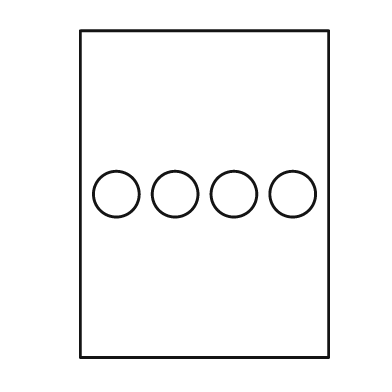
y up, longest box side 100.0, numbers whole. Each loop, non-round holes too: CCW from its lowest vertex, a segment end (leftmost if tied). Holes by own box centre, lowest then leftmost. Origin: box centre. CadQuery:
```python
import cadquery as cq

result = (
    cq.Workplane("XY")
    .moveTo(-38.0, -50.0)
    .lineTo(38.0, -50.0)
    .lineTo(38.0, 50.0)
    .lineTo(-38.0, 50.0)
    .close()
    .moveTo(-27.0, 0.0)
    .circle(7.0)
    .moveTo(-9.0, 0.0)
    .circle(7.0)
    .moveTo(9.0, 0.0)
    .circle(7.0)
    .moveTo(27.0, 0.0)
    .circle(7.0)
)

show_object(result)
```